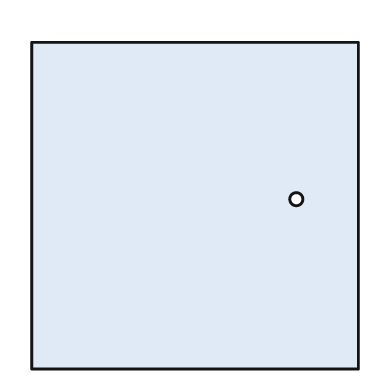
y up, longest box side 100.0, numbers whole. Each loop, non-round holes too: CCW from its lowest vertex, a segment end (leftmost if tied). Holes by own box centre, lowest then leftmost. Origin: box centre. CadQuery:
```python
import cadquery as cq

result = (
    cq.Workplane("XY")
    .moveTo(-50.0, -50.0)
    .lineTo(50.0, -50.0)
    .lineTo(50.0, 50.0)
    .lineTo(-50.0, 50.0)
    .close()
    .moveTo(31.0, 2.0)
    .circle(2.0)
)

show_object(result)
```